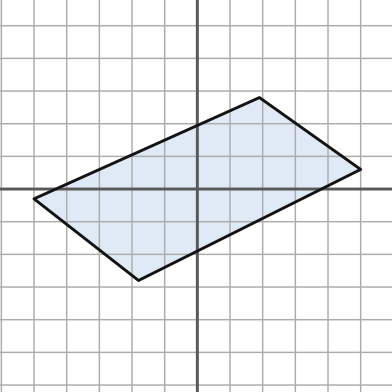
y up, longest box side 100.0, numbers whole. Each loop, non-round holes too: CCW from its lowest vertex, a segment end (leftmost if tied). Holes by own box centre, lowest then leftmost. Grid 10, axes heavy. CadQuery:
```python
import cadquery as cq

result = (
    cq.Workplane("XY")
    .moveTo(-18.0, -28.0)
    .lineTo(50.0, 6.0)
    .lineTo(19.0, 28.0)
    .lineTo(-50.0, -3.0)
    .close()
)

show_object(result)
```